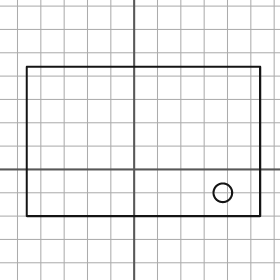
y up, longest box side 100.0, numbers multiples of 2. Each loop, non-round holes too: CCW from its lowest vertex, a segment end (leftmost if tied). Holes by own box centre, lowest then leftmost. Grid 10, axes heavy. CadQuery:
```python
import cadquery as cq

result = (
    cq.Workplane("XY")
    .moveTo(-46.0, -20.0)
    .lineTo(54.0, -20.0)
    .lineTo(54.0, 44.0)
    .lineTo(-46.0, 44.0)
    .close()
    .moveTo(38.0, -10.0)
    .circle(4.0)
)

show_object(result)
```